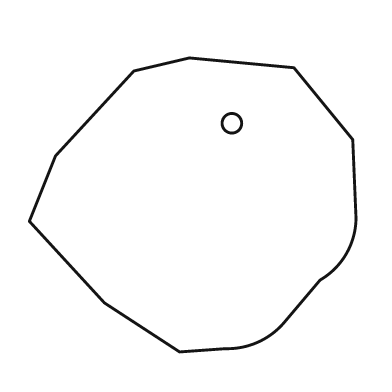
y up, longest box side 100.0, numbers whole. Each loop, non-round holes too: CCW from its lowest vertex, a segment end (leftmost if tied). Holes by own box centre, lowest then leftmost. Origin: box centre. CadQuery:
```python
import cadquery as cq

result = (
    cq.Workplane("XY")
    .moveTo(-4.0, -45.0)
    .lineTo(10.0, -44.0)
    .threePointArc((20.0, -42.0), (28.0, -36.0))
    .lineTo(39.0, -23.0)
    .threePointArc((47.0, -15.0), (50.0, -4.0))
    .lineTo(49.0, 20.0)
    .lineTo(31.0, 42.0)
    .lineTo(-1.0, 45.0)
    .lineTo(-18.0, 41.0)
    .lineTo(-42.0, 15.0)
    .lineTo(-50.0, -5.0)
    .lineTo(-27.0, -30.0)
    .close()
    .moveTo(12.0, 25.0)
    .circle(3.0)
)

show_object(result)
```